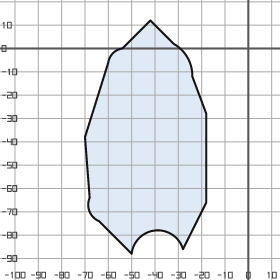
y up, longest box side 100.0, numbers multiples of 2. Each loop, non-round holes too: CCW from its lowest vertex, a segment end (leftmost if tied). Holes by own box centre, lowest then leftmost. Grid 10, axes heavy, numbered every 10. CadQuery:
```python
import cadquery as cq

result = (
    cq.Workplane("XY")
    .moveTo(-50.0, -88.0)
    .threePointArc((-40.0, -78.0), (-28.0, -86.0))
    .lineTo(-18.0, -66.0)
    .lineTo(-18.0, -28.0)
    .lineTo(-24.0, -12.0)
    .threePointArc((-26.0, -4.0), (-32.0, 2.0))
    .lineTo(-42.0, 12.0)
    .lineTo(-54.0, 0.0)
    .threePointArc((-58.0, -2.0), (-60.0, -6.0))
    .lineTo(-70.0, -38.0)
    .lineTo(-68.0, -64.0)
    .threePointArc((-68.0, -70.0), (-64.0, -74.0))
    .close()
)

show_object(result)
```